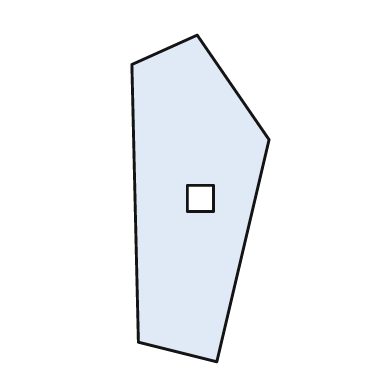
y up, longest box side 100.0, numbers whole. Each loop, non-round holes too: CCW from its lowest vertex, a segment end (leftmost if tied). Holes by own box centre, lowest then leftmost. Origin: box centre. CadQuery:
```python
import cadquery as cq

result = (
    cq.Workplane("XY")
    .moveTo(5.0, -50.0)
    .lineTo(21.0, 18.0)
    .lineTo(-1.0, 50.0)
    .lineTo(-21.0, 41.0)
    .lineTo(-19.0, -44.0)
    .close()
    .moveTo(-4.0, -4.0)
    .lineTo(4.0, -4.0)
    .lineTo(4.0, 4.0)
    .lineTo(-4.0, 4.0)
    .close()
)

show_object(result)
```